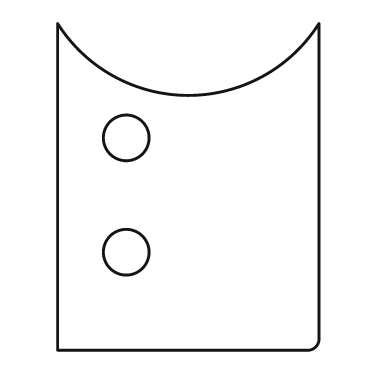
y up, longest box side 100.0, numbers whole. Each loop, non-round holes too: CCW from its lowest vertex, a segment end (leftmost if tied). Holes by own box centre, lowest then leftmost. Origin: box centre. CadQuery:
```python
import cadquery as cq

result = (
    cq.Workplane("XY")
    .moveTo(-40.0, -50.0)
    .lineTo(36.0, -50.0)
    .threePointArc((39.0, -49.0), (40.0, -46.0))
    .lineTo(40.0, 50.0)
    .threePointArc((0.0, 28.0), (-40.0, 50.0))
    .close()
    .moveTo(-19.0, -20.0)
    .circle(7.0)
    .moveTo(-19.0, 15.0)
    .circle(7.0)
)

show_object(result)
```